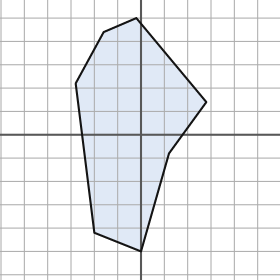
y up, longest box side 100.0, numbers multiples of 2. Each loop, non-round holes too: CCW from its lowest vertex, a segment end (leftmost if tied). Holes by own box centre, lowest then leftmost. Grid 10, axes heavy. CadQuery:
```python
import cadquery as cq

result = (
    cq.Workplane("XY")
    .moveTo(0.0, -50.0)
    .lineTo(12.0, -8.0)
    .lineTo(28.0, 14.0)
    .lineTo(-2.0, 50.0)
    .lineTo(-16.0, 44.0)
    .lineTo(-28.0, 22.0)
    .lineTo(-20.0, -42.0)
    .close()
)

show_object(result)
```